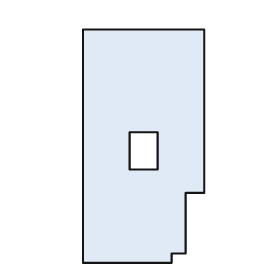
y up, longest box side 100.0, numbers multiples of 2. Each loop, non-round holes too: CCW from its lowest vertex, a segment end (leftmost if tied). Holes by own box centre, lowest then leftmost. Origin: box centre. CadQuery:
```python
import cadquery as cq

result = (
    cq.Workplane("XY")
    .moveTo(-26.0, -50.0)
    .lineTo(12.0, -50.0)
    .lineTo(12.0, -46.0)
    .lineTo(18.0, -46.0)
    .lineTo(18.0, -20.0)
    .lineTo(26.0, -20.0)
    .lineTo(26.0, 50.0)
    .lineTo(-26.0, 50.0)
    .close()
    .moveTo(-6.0, -10.0)
    .lineTo(6.0, -10.0)
    .lineTo(6.0, 6.0)
    .lineTo(-6.0, 6.0)
    .close()
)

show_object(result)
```